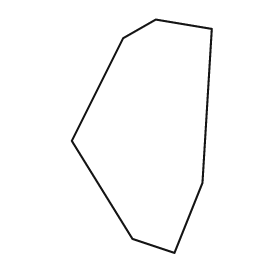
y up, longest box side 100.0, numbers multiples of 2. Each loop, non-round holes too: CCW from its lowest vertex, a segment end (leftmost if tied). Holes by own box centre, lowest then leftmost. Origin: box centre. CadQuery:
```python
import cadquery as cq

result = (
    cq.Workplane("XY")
    .moveTo(14.0, -50.0)
    .lineTo(26.0, -20.0)
    .lineTo(30.0, 46.0)
    .lineTo(6.0, 50.0)
    .lineTo(-8.0, 42.0)
    .lineTo(-30.0, -2.0)
    .lineTo(-4.0, -44.0)
    .close()
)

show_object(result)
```